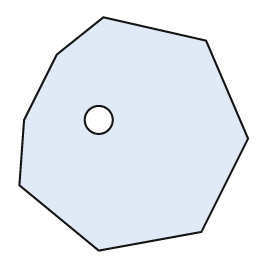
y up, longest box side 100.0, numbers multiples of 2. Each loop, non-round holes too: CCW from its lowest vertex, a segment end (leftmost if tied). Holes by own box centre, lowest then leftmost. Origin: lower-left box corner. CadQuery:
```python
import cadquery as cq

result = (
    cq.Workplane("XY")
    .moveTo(34.0, 0.0)
    .lineTo(78.0, 8.0)
    .lineTo(98.0, 48.0)
    .lineTo(80.0, 90.0)
    .lineTo(36.0, 100.0)
    .lineTo(16.0, 84.0)
    .lineTo(2.0, 56.0)
    .lineTo(0.0, 28.0)
    .close()
    .moveTo(34.0, 56.0)
    .circle(6.0)
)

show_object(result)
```